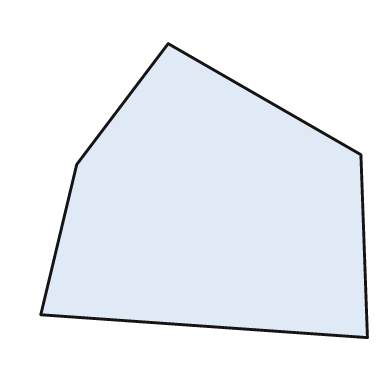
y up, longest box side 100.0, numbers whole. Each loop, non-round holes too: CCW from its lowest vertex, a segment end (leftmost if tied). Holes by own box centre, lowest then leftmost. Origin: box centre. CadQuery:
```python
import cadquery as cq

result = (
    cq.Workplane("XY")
    .moveTo(50.0, -45.0)
    .lineTo(48.0, 11.0)
    .lineTo(-11.0, 45.0)
    .lineTo(-39.0, 8.0)
    .lineTo(-50.0, -38.0)
    .close()
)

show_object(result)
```